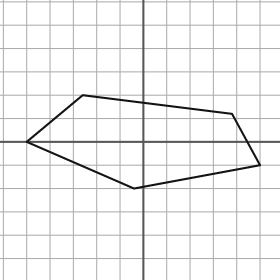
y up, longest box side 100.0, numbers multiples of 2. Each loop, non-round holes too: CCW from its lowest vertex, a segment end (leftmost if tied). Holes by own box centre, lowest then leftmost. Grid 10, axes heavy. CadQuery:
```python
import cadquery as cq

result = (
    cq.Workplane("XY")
    .moveTo(-4.0, -20.0)
    .lineTo(50.0, -10.0)
    .lineTo(38.0, 12.0)
    .lineTo(-26.0, 20.0)
    .lineTo(-50.0, 0.0)
    .close()
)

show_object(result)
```